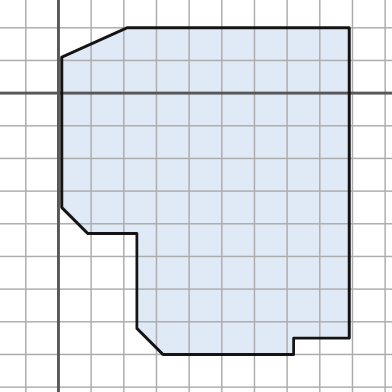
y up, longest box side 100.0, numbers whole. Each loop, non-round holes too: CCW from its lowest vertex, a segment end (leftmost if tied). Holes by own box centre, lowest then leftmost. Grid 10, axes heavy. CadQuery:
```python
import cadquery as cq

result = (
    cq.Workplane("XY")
    .moveTo(32.0, -80.0)
    .lineTo(72.0, -80.0)
    .lineTo(72.0, -75.0)
    .lineTo(89.0, -75.0)
    .lineTo(89.0, 20.0)
    .lineTo(21.0, 20.0)
    .lineTo(1.0, 11.0)
    .lineTo(1.0, -35.0)
    .lineTo(9.0, -43.0)
    .lineTo(24.0, -43.0)
    .lineTo(24.0, -72.0)
    .close()
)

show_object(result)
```